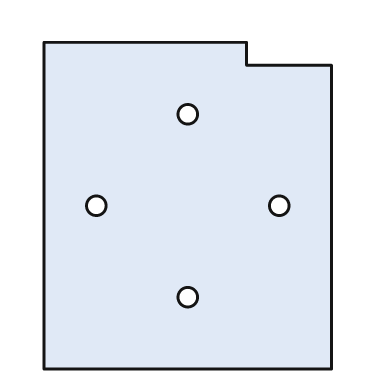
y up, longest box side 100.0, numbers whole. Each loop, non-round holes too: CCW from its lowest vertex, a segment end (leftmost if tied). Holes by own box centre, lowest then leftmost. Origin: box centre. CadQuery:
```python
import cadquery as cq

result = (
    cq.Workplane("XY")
    .moveTo(-44.0, -50.0)
    .lineTo(44.0, -50.0)
    .lineTo(44.0, 43.0)
    .lineTo(18.0, 43.0)
    .lineTo(18.0, 50.0)
    .lineTo(-44.0, 50.0)
    .close()
    .moveTo(0.0, -28.0)
    .circle(3.0)
    .moveTo(-28.0, 0.0)
    .circle(3.0)
    .moveTo(28.0, 0.0)
    .circle(3.0)
    .moveTo(0.0, 28.0)
    .circle(3.0)
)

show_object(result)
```